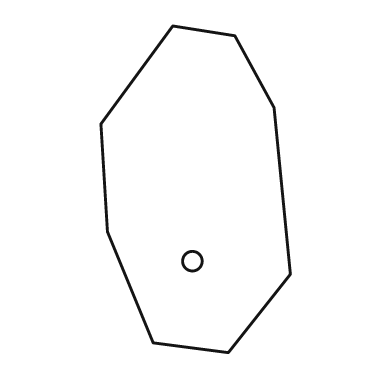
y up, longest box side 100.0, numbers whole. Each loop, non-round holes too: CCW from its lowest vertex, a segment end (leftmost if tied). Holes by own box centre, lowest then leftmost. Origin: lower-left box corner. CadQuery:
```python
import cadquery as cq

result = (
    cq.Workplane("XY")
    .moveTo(39.0, 0.0)
    .lineTo(58.0, 24.0)
    .lineTo(53.0, 75.0)
    .lineTo(41.0, 97.0)
    .lineTo(22.0, 100.0)
    .lineTo(0.0, 70.0)
    .lineTo(2.0, 37.0)
    .lineTo(16.0, 3.0)
    .close()
    .moveTo(28.0, 28.0)
    .circle(3.0)
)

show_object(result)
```